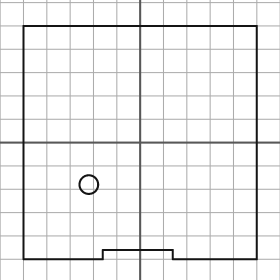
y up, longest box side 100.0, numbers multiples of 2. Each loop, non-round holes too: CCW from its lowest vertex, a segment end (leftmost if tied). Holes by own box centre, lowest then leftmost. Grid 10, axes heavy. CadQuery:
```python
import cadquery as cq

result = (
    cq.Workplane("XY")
    .moveTo(-50.0, -50.0)
    .lineTo(-16.0, -50.0)
    .lineTo(-16.0, -46.0)
    .lineTo(14.0, -46.0)
    .lineTo(14.0, -50.0)
    .lineTo(50.0, -50.0)
    .lineTo(50.0, 50.0)
    .lineTo(-50.0, 50.0)
    .close()
    .moveTo(-22.0, -18.0)
    .circle(4.0)
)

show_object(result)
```